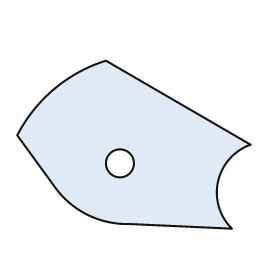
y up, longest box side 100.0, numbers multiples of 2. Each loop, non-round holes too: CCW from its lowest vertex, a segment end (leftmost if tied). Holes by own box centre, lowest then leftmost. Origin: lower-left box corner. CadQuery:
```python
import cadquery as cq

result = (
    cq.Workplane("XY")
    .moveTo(92.0, 0.0)
    .threePointArc((86.0, 20.0), (100.0, 36.0))
    .lineTo(38.0, 72.0)
    .threePointArc((16.0, 60.0), (0.0, 40.0))
    .lineTo(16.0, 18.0)
    .threePointArc((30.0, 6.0), (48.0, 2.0))
    .close()
    .moveTo(44.0, 28.0)
    .circle(6.0)
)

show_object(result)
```